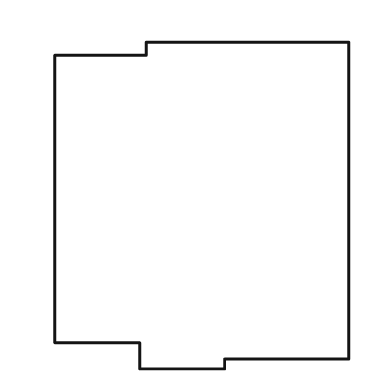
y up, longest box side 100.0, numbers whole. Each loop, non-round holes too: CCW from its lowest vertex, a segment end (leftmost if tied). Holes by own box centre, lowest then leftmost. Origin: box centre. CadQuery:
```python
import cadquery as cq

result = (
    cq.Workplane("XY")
    .moveTo(-19.0, -50.0)
    .lineTo(7.0, -50.0)
    .lineTo(7.0, -47.0)
    .lineTo(45.0, -47.0)
    .lineTo(45.0, 50.0)
    .lineTo(-17.0, 50.0)
    .lineTo(-17.0, 46.0)
    .lineTo(-45.0, 46.0)
    .lineTo(-45.0, -42.0)
    .lineTo(-19.0, -42.0)
    .close()
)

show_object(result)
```